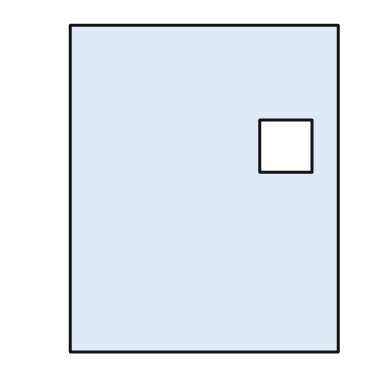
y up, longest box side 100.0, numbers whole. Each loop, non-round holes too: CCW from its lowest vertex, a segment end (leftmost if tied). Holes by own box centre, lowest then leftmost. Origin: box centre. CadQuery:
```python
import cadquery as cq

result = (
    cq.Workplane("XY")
    .moveTo(-41.0, -50.0)
    .lineTo(41.0, -50.0)
    .lineTo(41.0, 50.0)
    .lineTo(-41.0, 50.0)
    .close()
    .moveTo(17.0, 5.0)
    .lineTo(33.0, 5.0)
    .lineTo(33.0, 21.0)
    .lineTo(17.0, 21.0)
    .close()
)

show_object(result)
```